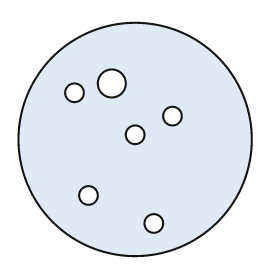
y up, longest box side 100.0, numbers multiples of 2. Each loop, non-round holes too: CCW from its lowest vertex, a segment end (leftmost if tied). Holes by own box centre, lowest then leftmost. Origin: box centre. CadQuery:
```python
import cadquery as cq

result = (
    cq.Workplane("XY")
    .moveTo(0.0, 0.0)
    .circle(50.0)
    .moveTo(8.0, -36.0)
    .circle(4.0)
    .moveTo(-20.0, -24.0)
    .circle(4.0)
    .moveTo(0.0, 2.0)
    .circle(4.0)
    .moveTo(16.0, 10.0)
    .circle(4.0)
    .moveTo(-26.0, 20.0)
    .circle(4.0)
    .moveTo(-10.0, 24.0)
    .circle(6.0)
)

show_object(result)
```